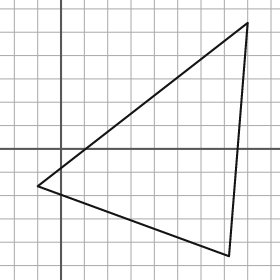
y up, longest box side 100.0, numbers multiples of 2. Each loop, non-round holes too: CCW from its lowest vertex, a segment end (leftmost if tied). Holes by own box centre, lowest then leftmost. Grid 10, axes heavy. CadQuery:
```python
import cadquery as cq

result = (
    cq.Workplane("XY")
    .moveTo(72.0, -46.0)
    .lineTo(80.0, 54.0)
    .lineTo(-10.0, -16.0)
    .close()
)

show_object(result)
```